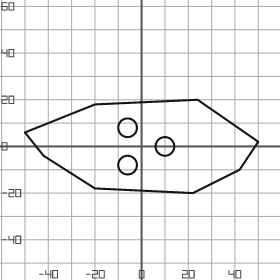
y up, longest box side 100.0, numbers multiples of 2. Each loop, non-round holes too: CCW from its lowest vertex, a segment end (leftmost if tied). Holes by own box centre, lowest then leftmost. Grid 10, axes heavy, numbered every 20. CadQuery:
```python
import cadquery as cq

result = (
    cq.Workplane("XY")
    .moveTo(22.0, -20.0)
    .lineTo(42.0, -10.0)
    .lineTo(50.0, 2.0)
    .lineTo(24.0, 20.0)
    .lineTo(-20.0, 18.0)
    .lineTo(-50.0, 6.0)
    .lineTo(-42.0, -4.0)
    .lineTo(-20.0, -18.0)
    .close()
    .moveTo(-6.0, -8.0)
    .circle(4.0)
    .moveTo(10.0, 0.0)
    .circle(4.0)
    .moveTo(-6.0, 8.0)
    .circle(4.0)
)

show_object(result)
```